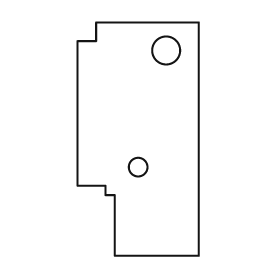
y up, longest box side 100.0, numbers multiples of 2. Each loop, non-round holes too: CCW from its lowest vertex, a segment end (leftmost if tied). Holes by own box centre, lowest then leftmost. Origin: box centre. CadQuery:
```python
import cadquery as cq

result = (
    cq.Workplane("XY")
    .moveTo(-10.0, -50.0)
    .lineTo(26.0, -50.0)
    .lineTo(26.0, 50.0)
    .lineTo(-18.0, 50.0)
    .lineTo(-18.0, 42.0)
    .lineTo(-26.0, 42.0)
    .lineTo(-26.0, -20.0)
    .lineTo(-14.0, -20.0)
    .lineTo(-14.0, -24.0)
    .lineTo(-10.0, -24.0)
    .close()
    .moveTo(0.0, -12.0)
    .circle(4.0)
    .moveTo(12.0, 38.0)
    .circle(6.0)
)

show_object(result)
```